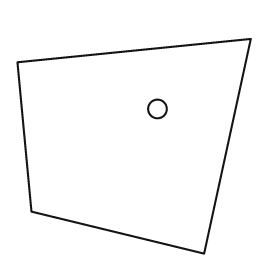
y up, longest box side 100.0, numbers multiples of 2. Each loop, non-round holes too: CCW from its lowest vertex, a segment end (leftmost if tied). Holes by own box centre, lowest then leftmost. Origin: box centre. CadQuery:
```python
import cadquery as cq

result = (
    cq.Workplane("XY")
    .moveTo(30.0, -46.0)
    .lineTo(50.0, 46.0)
    .lineTo(-50.0, 36.0)
    .lineTo(-44.0, -28.0)
    .close()
    .moveTo(10.0, 16.0)
    .circle(4.0)
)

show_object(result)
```